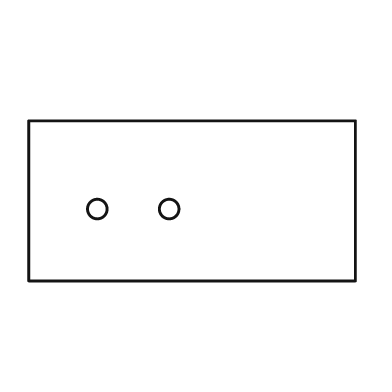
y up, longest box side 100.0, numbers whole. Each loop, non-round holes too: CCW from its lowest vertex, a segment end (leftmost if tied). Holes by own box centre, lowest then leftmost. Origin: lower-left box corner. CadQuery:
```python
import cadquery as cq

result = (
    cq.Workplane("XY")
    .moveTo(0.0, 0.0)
    .lineTo(100.0, 0.0)
    .lineTo(100.0, 49.0)
    .lineTo(0.0, 49.0)
    .close()
    .moveTo(21.0, 22.0)
    .circle(3.0)
    .moveTo(43.0, 22.0)
    .circle(3.0)
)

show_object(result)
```